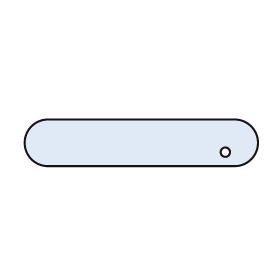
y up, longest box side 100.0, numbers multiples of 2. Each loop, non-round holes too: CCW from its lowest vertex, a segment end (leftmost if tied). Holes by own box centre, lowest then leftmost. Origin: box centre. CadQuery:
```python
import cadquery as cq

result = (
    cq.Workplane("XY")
    .moveTo(-40.0, -10.0)
    .lineTo(40.0, -10.0)
    .threePointArc((50.0, 0.0), (40.0, 10.0))
    .lineTo(-40.0, 10.0)
    .threePointArc((-50.0, 0.0), (-40.0, -10.0))
    .close()
    .moveTo(36.0, -4.0)
    .circle(2.0)
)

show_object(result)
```